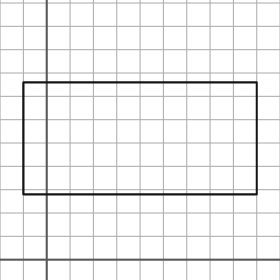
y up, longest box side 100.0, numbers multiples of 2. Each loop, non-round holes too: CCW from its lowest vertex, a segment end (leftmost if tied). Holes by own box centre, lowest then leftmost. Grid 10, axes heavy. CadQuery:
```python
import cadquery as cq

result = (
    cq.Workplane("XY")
    .moveTo(-10.0, 28.0)
    .lineTo(90.0, 28.0)
    .lineTo(90.0, 76.0)
    .lineTo(-10.0, 76.0)
    .close()
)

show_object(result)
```